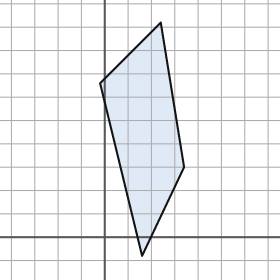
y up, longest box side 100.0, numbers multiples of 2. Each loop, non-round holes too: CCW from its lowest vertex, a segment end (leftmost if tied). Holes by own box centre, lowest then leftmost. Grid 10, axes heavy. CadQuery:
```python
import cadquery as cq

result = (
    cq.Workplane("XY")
    .moveTo(16.0, -8.0)
    .lineTo(34.0, 30.0)
    .lineTo(24.0, 92.0)
    .lineTo(-2.0, 66.0)
    .close()
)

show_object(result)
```